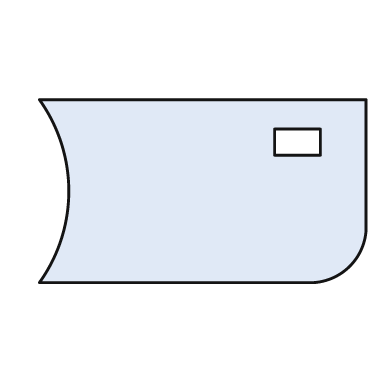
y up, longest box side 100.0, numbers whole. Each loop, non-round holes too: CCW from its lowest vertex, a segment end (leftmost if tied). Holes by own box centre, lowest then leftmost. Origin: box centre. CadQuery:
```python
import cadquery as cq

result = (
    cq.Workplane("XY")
    .moveTo(-50.0, -28.0)
    .lineTo(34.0, -28.0)
    .threePointArc((45.0, -23.0), (50.0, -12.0))
    .lineTo(50.0, 28.0)
    .lineTo(-50.0, 28.0)
    .threePointArc((-41.0, 0.0), (-50.0, -28.0))
    .close()
    .moveTo(22.0, 11.0)
    .lineTo(36.0, 11.0)
    .lineTo(36.0, 19.0)
    .lineTo(22.0, 19.0)
    .close()
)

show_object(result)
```